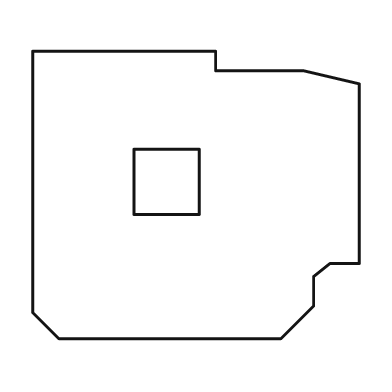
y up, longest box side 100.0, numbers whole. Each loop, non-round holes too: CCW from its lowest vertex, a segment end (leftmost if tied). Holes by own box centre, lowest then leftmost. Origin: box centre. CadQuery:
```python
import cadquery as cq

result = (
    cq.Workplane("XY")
    .moveTo(-42.0, -44.0)
    .lineTo(26.0, -44.0)
    .lineTo(36.0, -34.0)
    .lineTo(36.0, -25.0)
    .lineTo(41.0, -21.0)
    .lineTo(50.0, -21.0)
    .lineTo(50.0, 34.0)
    .lineTo(33.0, 38.0)
    .lineTo(6.0, 38.0)
    .lineTo(6.0, 44.0)
    .lineTo(-50.0, 44.0)
    .lineTo(-50.0, -36.0)
    .close()
    .moveTo(-19.0, -6.0)
    .lineTo(1.0, -6.0)
    .lineTo(1.0, 14.0)
    .lineTo(-19.0, 14.0)
    .close()
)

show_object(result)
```